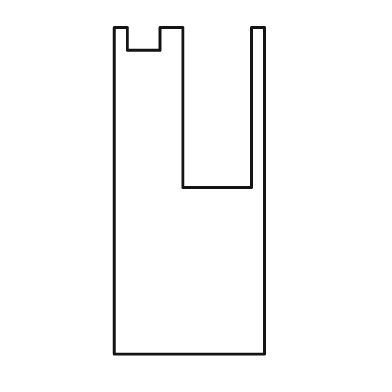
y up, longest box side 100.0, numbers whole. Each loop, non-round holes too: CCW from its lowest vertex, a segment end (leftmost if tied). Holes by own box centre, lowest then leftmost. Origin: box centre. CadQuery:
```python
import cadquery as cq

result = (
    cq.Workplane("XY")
    .moveTo(-23.0, -50.0)
    .lineTo(23.0, -50.0)
    .lineTo(23.0, 50.0)
    .lineTo(19.0, 50.0)
    .lineTo(19.0, 1.0)
    .lineTo(-2.0, 1.0)
    .lineTo(-2.0, 50.0)
    .lineTo(-9.0, 50.0)
    .lineTo(-9.0, 43.0)
    .lineTo(-19.0, 43.0)
    .lineTo(-19.0, 50.0)
    .lineTo(-23.0, 50.0)
    .close()
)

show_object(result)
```